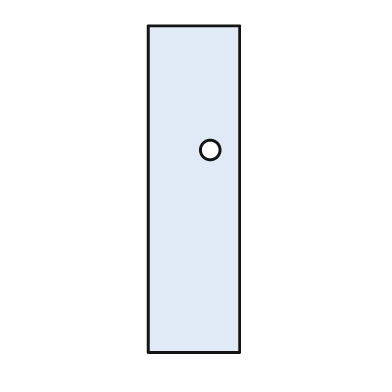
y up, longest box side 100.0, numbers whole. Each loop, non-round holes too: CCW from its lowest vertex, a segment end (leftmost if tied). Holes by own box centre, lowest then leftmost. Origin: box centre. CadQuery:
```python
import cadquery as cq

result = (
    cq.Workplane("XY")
    .moveTo(-14.0, -50.0)
    .lineTo(14.0, -50.0)
    .lineTo(14.0, 50.0)
    .lineTo(-14.0, 50.0)
    .close()
    .moveTo(5.0, 12.0)
    .circle(3.0)
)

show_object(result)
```